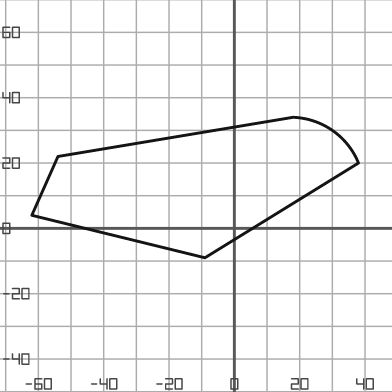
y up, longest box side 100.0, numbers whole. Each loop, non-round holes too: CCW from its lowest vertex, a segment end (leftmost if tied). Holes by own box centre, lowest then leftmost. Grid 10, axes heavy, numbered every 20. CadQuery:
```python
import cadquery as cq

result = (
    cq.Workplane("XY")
    .moveTo(-9.0, -9.0)
    .lineTo(38.0, 20.0)
    .threePointArc((30.0, 30.0), (18.0, 34.0))
    .lineTo(-54.0, 22.0)
    .lineTo(-62.0, 4.0)
    .close()
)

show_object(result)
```